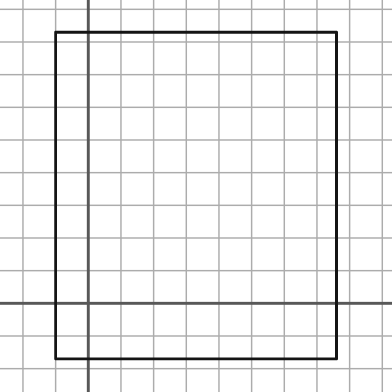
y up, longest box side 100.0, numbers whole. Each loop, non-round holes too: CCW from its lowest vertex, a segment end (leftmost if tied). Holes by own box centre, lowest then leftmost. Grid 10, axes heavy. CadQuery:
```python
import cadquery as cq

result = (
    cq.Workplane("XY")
    .moveTo(-10.0, -17.0)
    .lineTo(76.0, -17.0)
    .lineTo(76.0, 83.0)
    .lineTo(-10.0, 83.0)
    .close()
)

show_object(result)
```